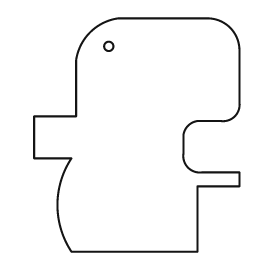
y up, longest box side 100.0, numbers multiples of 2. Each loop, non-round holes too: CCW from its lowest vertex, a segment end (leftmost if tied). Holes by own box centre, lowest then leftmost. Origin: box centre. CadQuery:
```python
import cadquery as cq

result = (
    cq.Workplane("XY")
    .moveTo(-28.0, -50.0)
    .lineTo(26.0, -50.0)
    .lineTo(26.0, -22.0)
    .lineTo(44.0, -22.0)
    .lineTo(44.0, -16.0)
    .lineTo(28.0, -16.0)
    .threePointArc((22.0, -14.0), (20.0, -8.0))
    .lineTo(20.0, 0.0)
    .threePointArc((22.0, 4.0), (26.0, 6.0))
    .lineTo(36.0, 6.0)
    .threePointArc((42.0, 8.0), (44.0, 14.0))
    .lineTo(44.0, 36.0)
    .threePointArc((40.0, 46.0), (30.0, 50.0))
    .lineTo(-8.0, 50.0)
    .threePointArc((-20.0, 44.0), (-26.0, 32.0))
    .lineTo(-26.0, 8.0)
    .lineTo(-44.0, 8.0)
    .lineTo(-44.0, -10.0)
    .lineTo(-28.0, -10.0)
    .threePointArc((-34.0, -30.0), (-28.0, -50.0))
    .close()
    .moveTo(-12.0, 38.0)
    .circle(2.0)
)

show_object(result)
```